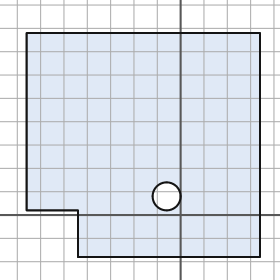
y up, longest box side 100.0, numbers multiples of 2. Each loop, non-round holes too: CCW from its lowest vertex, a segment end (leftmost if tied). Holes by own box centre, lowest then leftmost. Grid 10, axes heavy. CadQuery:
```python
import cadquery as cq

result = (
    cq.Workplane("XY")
    .moveTo(-44.0, -18.0)
    .lineTo(34.0, -18.0)
    .lineTo(34.0, 78.0)
    .lineTo(-66.0, 78.0)
    .lineTo(-66.0, 2.0)
    .lineTo(-44.0, 2.0)
    .close()
    .moveTo(-6.0, 8.0)
    .circle(6.0)
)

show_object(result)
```